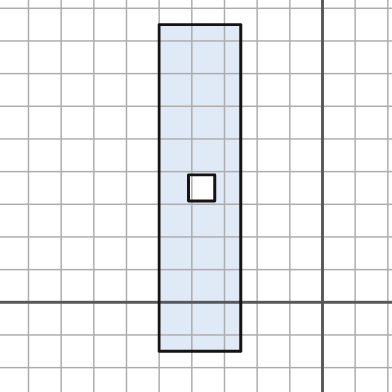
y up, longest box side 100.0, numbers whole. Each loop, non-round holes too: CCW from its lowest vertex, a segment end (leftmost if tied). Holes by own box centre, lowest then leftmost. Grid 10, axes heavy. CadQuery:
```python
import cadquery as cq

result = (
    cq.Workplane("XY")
    .moveTo(-50.0, -15.0)
    .lineTo(-25.0, -15.0)
    .lineTo(-25.0, 85.0)
    .lineTo(-50.0, 85.0)
    .close()
    .moveTo(-41.0, 31.0)
    .lineTo(-33.0, 31.0)
    .lineTo(-33.0, 39.0)
    .lineTo(-41.0, 39.0)
    .close()
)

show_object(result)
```